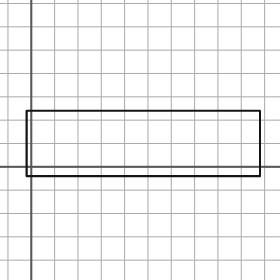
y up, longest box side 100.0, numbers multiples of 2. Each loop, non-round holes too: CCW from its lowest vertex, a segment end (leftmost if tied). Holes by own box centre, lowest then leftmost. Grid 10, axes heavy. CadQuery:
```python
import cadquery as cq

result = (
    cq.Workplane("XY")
    .moveTo(-2.0, -4.0)
    .lineTo(98.0, -4.0)
    .lineTo(98.0, 24.0)
    .lineTo(-2.0, 24.0)
    .close()
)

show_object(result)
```